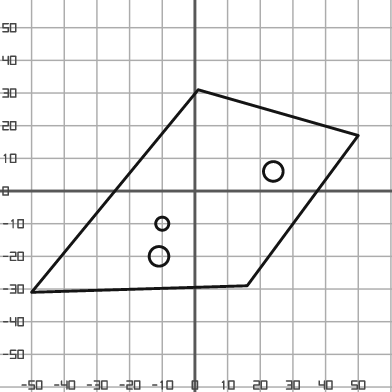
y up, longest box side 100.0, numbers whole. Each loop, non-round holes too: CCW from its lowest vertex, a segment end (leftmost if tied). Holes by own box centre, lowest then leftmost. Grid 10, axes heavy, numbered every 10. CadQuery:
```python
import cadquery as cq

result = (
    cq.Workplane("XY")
    .moveTo(-50.0, -31.0)
    .lineTo(16.0, -29.0)
    .lineTo(50.0, 17.0)
    .lineTo(1.0, 31.0)
    .close()
    .moveTo(-11.0, -20.0)
    .circle(3.0)
    .moveTo(-10.0, -10.0)
    .circle(2.0)
    .moveTo(24.0, 6.0)
    .circle(3.0)
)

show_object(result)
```